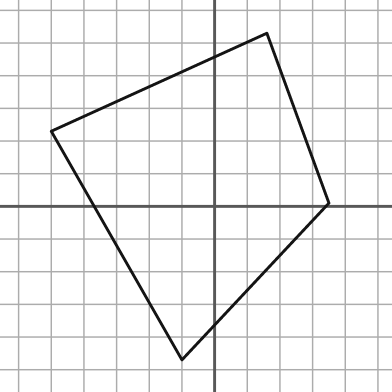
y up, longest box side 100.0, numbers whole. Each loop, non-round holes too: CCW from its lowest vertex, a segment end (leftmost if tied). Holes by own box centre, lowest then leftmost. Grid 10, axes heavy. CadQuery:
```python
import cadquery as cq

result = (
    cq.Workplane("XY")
    .moveTo(-10.0, -47.0)
    .lineTo(35.0, 1.0)
    .lineTo(16.0, 53.0)
    .lineTo(-50.0, 23.0)
    .close()
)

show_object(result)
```